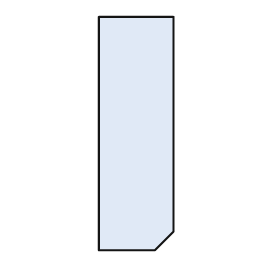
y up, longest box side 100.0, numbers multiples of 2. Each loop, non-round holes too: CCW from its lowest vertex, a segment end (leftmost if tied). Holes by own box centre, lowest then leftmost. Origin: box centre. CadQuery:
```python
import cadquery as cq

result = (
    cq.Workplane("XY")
    .moveTo(-16.0, -50.0)
    .lineTo(8.0, -50.0)
    .lineTo(16.0, -42.0)
    .lineTo(16.0, 50.0)
    .lineTo(-16.0, 50.0)
    .close()
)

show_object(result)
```